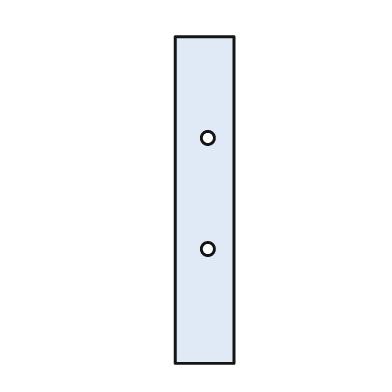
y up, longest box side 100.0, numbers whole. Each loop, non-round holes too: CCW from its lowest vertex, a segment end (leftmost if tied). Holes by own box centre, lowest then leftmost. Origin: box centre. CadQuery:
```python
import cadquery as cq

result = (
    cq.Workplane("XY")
    .moveTo(-9.0, -50.0)
    .lineTo(9.0, -50.0)
    .lineTo(9.0, 50.0)
    .lineTo(-9.0, 50.0)
    .close()
    .moveTo(1.0, -15.0)
    .circle(2.0)
    .moveTo(1.0, 19.0)
    .circle(2.0)
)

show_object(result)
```